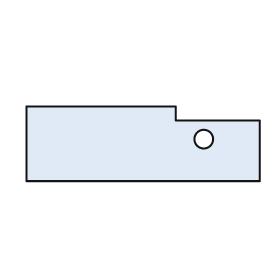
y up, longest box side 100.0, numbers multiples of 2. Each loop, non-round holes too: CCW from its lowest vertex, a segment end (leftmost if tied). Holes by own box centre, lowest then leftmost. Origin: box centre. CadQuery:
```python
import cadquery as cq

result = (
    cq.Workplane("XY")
    .moveTo(-50.0, -16.0)
    .lineTo(50.0, -16.0)
    .lineTo(50.0, 10.0)
    .lineTo(14.0, 10.0)
    .lineTo(14.0, 16.0)
    .lineTo(-50.0, 16.0)
    .close()
    .moveTo(26.0, 2.0)
    .circle(4.0)
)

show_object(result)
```